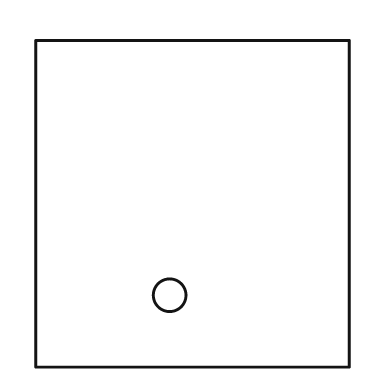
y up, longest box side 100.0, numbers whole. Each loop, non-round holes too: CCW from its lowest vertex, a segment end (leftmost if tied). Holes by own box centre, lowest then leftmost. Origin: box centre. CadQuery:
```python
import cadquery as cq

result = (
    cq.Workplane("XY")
    .moveTo(-48.0, -50.0)
    .lineTo(48.0, -50.0)
    .lineTo(48.0, 50.0)
    .lineTo(-48.0, 50.0)
    .close()
    .moveTo(-7.0, -28.0)
    .circle(5.0)
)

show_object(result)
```